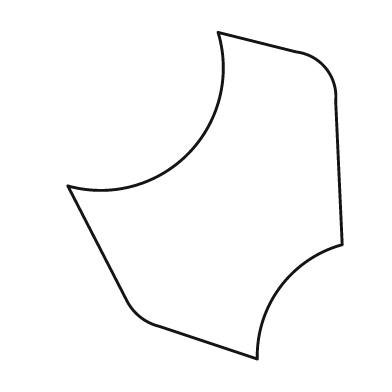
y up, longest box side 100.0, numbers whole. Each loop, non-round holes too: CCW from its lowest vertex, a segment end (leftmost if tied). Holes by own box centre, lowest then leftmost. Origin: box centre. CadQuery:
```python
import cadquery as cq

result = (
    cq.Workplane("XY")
    .moveTo(16.0, -50.0)
    .threePointArc((23.0, -28.0), (42.0, -15.0))
    .lineTo(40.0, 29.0)
    .threePointArc((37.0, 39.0), (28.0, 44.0))
    .lineTo(4.0, 50.0)
    .threePointArc((-5.0, 13.0), (-42.0, 3.0))
    .lineTo(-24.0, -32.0)
    .threePointArc((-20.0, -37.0), (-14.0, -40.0))
    .close()
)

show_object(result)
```